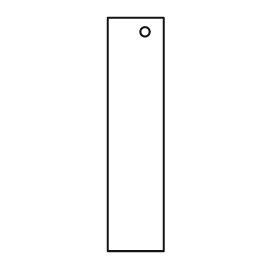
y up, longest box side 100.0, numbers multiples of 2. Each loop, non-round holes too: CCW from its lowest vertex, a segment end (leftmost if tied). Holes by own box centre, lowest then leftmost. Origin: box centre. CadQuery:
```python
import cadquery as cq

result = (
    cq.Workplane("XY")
    .moveTo(-12.0, -50.0)
    .lineTo(12.0, -50.0)
    .lineTo(12.0, 50.0)
    .lineTo(-12.0, 50.0)
    .close()
    .moveTo(4.0, 44.0)
    .circle(2.0)
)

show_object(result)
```